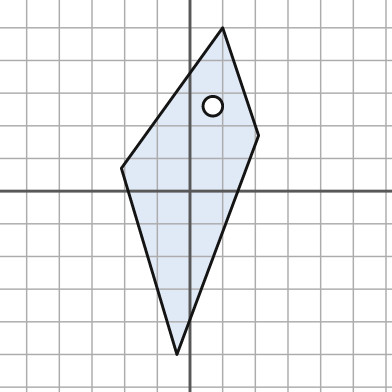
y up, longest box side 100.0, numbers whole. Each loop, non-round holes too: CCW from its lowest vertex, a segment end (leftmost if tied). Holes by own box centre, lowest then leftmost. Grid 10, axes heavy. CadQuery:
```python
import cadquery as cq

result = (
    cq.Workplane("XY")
    .moveTo(-4.0, -50.0)
    .lineTo(21.0, 17.0)
    .lineTo(10.0, 50.0)
    .lineTo(-21.0, 7.0)
    .close()
    .moveTo(7.0, 26.0)
    .circle(3.0)
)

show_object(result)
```